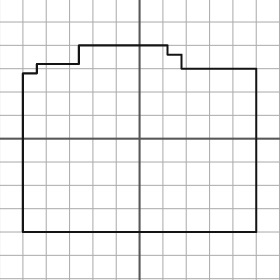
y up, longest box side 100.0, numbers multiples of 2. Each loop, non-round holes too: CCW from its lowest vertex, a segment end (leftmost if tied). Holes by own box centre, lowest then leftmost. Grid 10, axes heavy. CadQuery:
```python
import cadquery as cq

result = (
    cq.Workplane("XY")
    .moveTo(-50.0, -40.0)
    .lineTo(50.0, -40.0)
    .lineTo(50.0, 30.0)
    .lineTo(18.0, 30.0)
    .lineTo(18.0, 36.0)
    .lineTo(12.0, 36.0)
    .lineTo(12.0, 40.0)
    .lineTo(-26.0, 40.0)
    .lineTo(-26.0, 32.0)
    .lineTo(-44.0, 32.0)
    .lineTo(-44.0, 28.0)
    .lineTo(-50.0, 28.0)
    .close()
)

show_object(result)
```